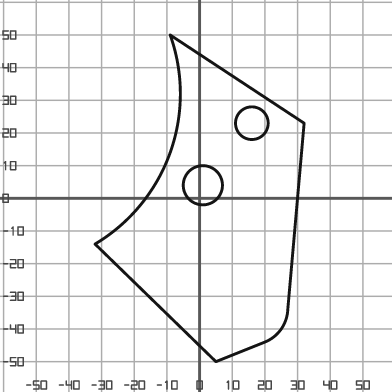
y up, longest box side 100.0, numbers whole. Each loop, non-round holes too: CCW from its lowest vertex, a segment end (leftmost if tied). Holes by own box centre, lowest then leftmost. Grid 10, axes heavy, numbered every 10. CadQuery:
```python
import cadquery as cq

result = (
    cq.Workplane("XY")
    .moveTo(5.0, -50.0)
    .lineTo(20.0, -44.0)
    .threePointArc((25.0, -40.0), (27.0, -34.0))
    .lineTo(32.0, 23.0)
    .lineTo(-9.0, 50.0)
    .threePointArc((-9.0, 14.0), (-32.0, -14.0))
    .close()
    .moveTo(1.0, 4.0)
    .circle(6.0)
    .moveTo(16.0, 23.0)
    .circle(5.0)
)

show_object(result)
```